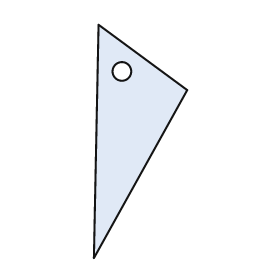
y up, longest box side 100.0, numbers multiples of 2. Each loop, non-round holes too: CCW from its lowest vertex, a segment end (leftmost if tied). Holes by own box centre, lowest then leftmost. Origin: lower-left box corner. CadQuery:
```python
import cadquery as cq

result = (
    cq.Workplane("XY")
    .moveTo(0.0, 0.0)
    .lineTo(40.0, 72.0)
    .lineTo(2.0, 100.0)
    .close()
    .moveTo(12.0, 80.0)
    .circle(4.0)
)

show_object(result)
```